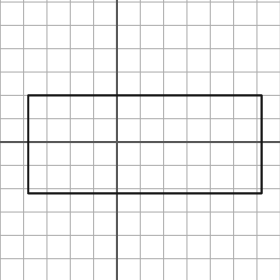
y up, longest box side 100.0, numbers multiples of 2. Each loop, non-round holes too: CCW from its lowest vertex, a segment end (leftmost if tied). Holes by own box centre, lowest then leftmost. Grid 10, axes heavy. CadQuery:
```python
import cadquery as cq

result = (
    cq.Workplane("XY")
    .moveTo(-38.0, -22.0)
    .lineTo(62.0, -22.0)
    .lineTo(62.0, 20.0)
    .lineTo(-38.0, 20.0)
    .close()
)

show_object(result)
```